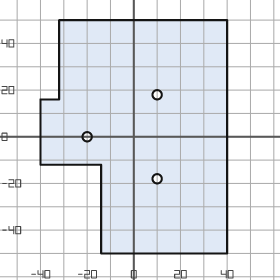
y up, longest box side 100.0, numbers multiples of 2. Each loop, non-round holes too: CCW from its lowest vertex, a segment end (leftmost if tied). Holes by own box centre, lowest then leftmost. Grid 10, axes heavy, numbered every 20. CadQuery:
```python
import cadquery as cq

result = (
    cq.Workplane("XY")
    .moveTo(-14.0, -50.0)
    .lineTo(40.0, -50.0)
    .lineTo(40.0, 50.0)
    .lineTo(-32.0, 50.0)
    .lineTo(-32.0, 16.0)
    .lineTo(-40.0, 16.0)
    .lineTo(-40.0, -12.0)
    .lineTo(-14.0, -12.0)
    .close()
    .moveTo(10.0, -18.0)
    .circle(2.0)
    .moveTo(-20.0, 0.0)
    .circle(2.0)
    .moveTo(10.0, 18.0)
    .circle(2.0)
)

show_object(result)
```